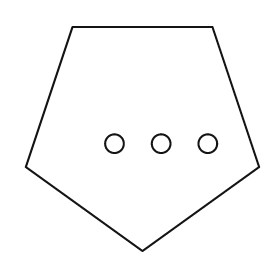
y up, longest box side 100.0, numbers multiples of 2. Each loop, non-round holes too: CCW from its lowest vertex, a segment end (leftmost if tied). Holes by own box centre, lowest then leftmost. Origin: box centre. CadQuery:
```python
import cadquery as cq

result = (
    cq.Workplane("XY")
    .moveTo(0.0, -48.0)
    .lineTo(50.0, -12.0)
    .lineTo(30.0, 48.0)
    .lineTo(-30.0, 48.0)
    .lineTo(-50.0, -12.0)
    .close()
    .moveTo(-12.0, -2.0)
    .circle(4.0)
    .moveTo(8.0, -2.0)
    .circle(4.0)
    .moveTo(28.0, -2.0)
    .circle(4.0)
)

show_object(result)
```